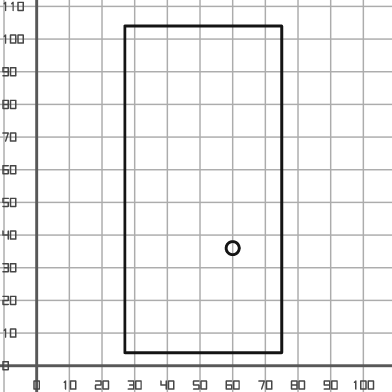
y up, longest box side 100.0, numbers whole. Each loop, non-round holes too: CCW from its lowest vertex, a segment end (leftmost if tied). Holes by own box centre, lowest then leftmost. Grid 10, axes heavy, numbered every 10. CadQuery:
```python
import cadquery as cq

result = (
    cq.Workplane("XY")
    .moveTo(27.0, 4.0)
    .lineTo(75.0, 4.0)
    .lineTo(75.0, 104.0)
    .lineTo(27.0, 104.0)
    .close()
    .moveTo(60.0, 36.0)
    .circle(2.0)
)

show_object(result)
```